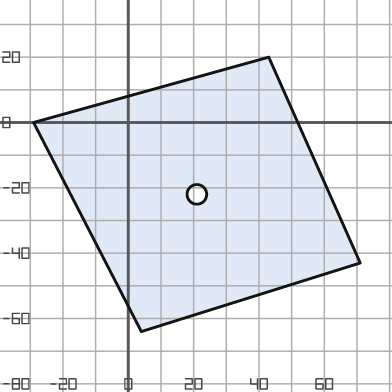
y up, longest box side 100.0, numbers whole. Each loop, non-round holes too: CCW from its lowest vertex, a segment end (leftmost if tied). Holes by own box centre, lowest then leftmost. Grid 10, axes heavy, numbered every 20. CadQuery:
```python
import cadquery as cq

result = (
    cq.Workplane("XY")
    .moveTo(4.0, -64.0)
    .lineTo(71.0, -43.0)
    .lineTo(43.0, 20.0)
    .lineTo(-29.0, 0.0)
    .close()
    .moveTo(21.0, -22.0)
    .circle(3.0)
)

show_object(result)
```